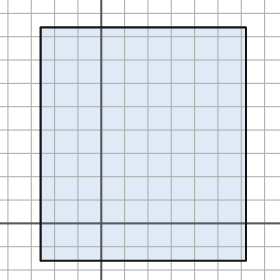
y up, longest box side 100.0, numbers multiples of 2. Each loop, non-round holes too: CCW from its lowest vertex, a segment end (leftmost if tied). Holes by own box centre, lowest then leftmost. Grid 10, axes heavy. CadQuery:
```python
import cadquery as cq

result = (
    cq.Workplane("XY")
    .moveTo(-26.0, -16.0)
    .lineTo(62.0, -16.0)
    .lineTo(62.0, 84.0)
    .lineTo(-26.0, 84.0)
    .close()
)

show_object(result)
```